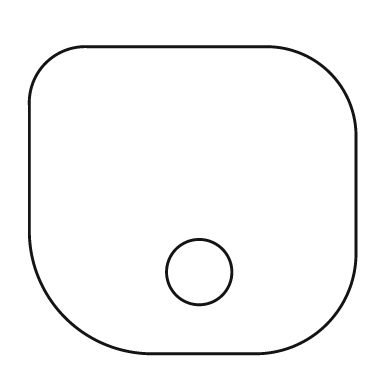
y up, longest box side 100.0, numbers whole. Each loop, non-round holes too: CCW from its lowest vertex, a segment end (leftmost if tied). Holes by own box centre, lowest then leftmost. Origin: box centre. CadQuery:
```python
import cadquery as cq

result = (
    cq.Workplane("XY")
    .moveTo(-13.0, -47.0)
    .lineTo(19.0, -47.0)
    .threePointArc((41.0, -38.0), (50.0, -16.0))
    .lineTo(50.0, 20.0)
    .threePointArc((42.0, 39.0), (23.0, 47.0))
    .lineTo(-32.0, 47.0)
    .threePointArc((-45.0, 42.0), (-50.0, 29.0))
    .lineTo(-50.0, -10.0)
    .threePointArc((-39.0, -36.0), (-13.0, -47.0))
    .close()
    .moveTo(2.0, -22.0)
    .circle(10.0)
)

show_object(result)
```